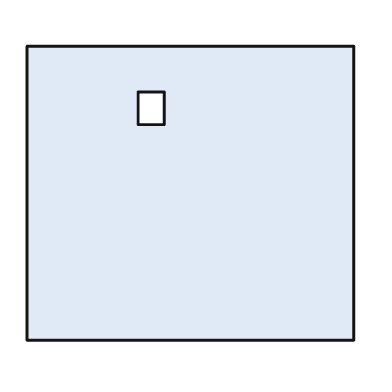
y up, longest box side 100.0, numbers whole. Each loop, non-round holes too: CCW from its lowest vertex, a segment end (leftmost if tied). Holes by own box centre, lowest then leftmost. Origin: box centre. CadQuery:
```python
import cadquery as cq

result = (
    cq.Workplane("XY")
    .moveTo(-50.0, -45.0)
    .lineTo(50.0, -45.0)
    .lineTo(50.0, 45.0)
    .lineTo(-50.0, 45.0)
    .close()
    .moveTo(-16.0, 21.0)
    .lineTo(-8.0, 21.0)
    .lineTo(-8.0, 31.0)
    .lineTo(-16.0, 31.0)
    .close()
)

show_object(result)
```